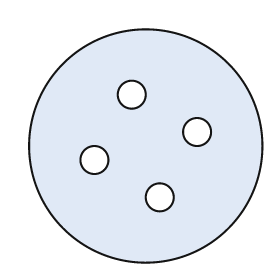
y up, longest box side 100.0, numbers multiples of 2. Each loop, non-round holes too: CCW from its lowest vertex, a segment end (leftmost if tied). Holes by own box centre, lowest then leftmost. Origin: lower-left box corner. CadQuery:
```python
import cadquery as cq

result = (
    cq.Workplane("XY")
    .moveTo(50.0, 50.0)
    .circle(50.0)
    .moveTo(56.0, 28.0)
    .circle(6.0)
    .moveTo(28.0, 44.0)
    .circle(6.0)
    .moveTo(72.0, 56.0)
    .circle(6.0)
    .moveTo(44.0, 72.0)
    .circle(6.0)
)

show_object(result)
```